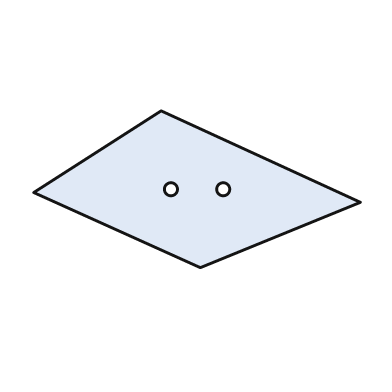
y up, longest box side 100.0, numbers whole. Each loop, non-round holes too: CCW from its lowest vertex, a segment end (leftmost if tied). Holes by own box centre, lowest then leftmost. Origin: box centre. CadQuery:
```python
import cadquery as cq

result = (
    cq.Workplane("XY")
    .moveTo(1.0, -24.0)
    .lineTo(50.0, -4.0)
    .lineTo(-11.0, 24.0)
    .lineTo(-50.0, -1.0)
    .close()
    .moveTo(-8.0, 0.0)
    .circle(2.0)
    .moveTo(8.0, 0.0)
    .circle(2.0)
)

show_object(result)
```